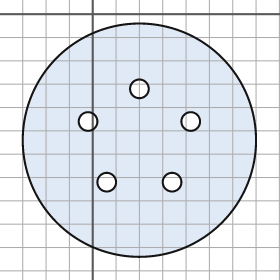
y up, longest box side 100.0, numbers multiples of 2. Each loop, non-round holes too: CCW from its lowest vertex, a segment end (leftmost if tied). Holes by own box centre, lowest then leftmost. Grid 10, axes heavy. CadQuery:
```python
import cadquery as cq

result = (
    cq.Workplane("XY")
    .moveTo(20.0, -54.0)
    .circle(50.0)
    .moveTo(6.0, -72.0)
    .circle(4.0)
    .moveTo(34.0, -72.0)
    .circle(4.0)
    .moveTo(-2.0, -46.0)
    .circle(4.0)
    .moveTo(42.0, -46.0)
    .circle(4.0)
    .moveTo(20.0, -32.0)
    .circle(4.0)
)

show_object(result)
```